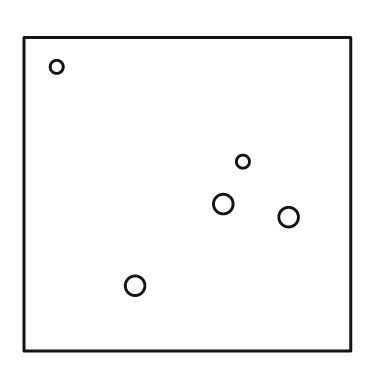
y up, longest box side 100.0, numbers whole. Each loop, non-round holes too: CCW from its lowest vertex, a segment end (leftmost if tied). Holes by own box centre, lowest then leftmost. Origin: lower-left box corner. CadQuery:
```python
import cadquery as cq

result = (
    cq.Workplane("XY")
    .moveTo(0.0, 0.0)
    .lineTo(100.0, 0.0)
    .lineTo(100.0, 96.0)
    .lineTo(0.0, 96.0)
    .close()
    .moveTo(34.0, 20.0)
    .circle(3.0)
    .moveTo(81.0, 41.0)
    .circle(3.0)
    .moveTo(61.0, 45.0)
    .circle(3.0)
    .moveTo(67.0, 58.0)
    .circle(2.0)
    .moveTo(10.0, 87.0)
    .circle(2.0)
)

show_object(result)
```